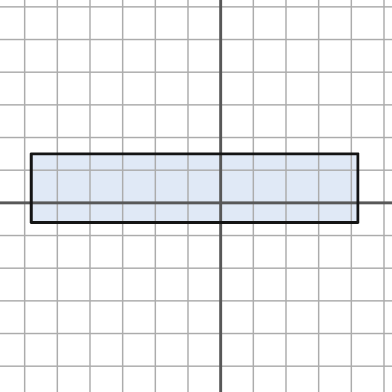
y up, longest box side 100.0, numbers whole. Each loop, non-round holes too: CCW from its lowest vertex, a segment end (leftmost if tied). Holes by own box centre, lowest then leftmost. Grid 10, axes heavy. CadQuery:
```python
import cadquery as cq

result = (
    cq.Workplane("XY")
    .moveTo(-58.0, -6.0)
    .lineTo(42.0, -6.0)
    .lineTo(42.0, 15.0)
    .lineTo(-58.0, 15.0)
    .close()
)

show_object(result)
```